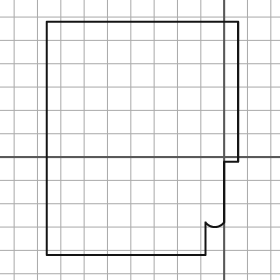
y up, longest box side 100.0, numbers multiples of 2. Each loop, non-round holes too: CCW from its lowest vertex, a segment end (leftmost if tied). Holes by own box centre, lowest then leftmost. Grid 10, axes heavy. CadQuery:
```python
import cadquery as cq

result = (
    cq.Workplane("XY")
    .moveTo(-76.0, -42.0)
    .lineTo(-8.0, -42.0)
    .lineTo(-8.0, -28.0)
    .threePointArc((-4.0, -30.0), (0.0, -28.0))
    .lineTo(0.0, -2.0)
    .lineTo(6.0, -2.0)
    .lineTo(6.0, 58.0)
    .lineTo(-76.0, 58.0)
    .close()
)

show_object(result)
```